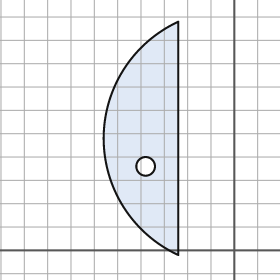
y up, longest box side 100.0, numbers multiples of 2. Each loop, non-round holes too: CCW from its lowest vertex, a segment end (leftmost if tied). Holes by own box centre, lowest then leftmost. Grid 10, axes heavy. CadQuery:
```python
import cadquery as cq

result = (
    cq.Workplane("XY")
    .moveTo(-24.0, -2.0)
    .lineTo(-24.0, 98.0)
    .threePointArc((-56.0, 48.0), (-24.0, -2.0))
    .close()
    .moveTo(-38.0, 36.0)
    .circle(4.0)
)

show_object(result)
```